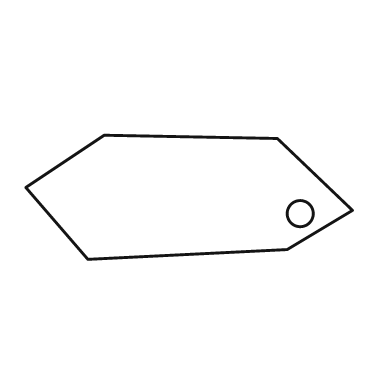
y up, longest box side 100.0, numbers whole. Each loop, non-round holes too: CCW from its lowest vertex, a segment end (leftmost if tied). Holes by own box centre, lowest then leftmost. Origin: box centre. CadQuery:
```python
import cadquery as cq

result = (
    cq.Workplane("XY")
    .moveTo(-31.0, -19.0)
    .lineTo(30.0, -16.0)
    .lineTo(50.0, -4.0)
    .lineTo(27.0, 18.0)
    .lineTo(-26.0, 19.0)
    .lineTo(-50.0, 3.0)
    .close()
    .moveTo(34.0, -5.0)
    .circle(4.0)
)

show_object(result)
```